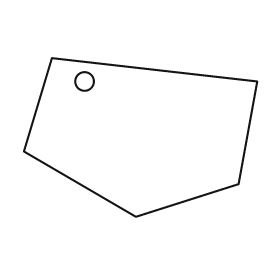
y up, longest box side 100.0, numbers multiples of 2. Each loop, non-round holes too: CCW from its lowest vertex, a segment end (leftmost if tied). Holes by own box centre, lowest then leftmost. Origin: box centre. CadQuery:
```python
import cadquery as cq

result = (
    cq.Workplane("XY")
    .moveTo(-2.0, -34.0)
    .lineTo(42.0, -20.0)
    .lineTo(50.0, 24.0)
    .lineTo(-38.0, 34.0)
    .lineTo(-50.0, -6.0)
    .close()
    .moveTo(-24.0, 24.0)
    .circle(4.0)
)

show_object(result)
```